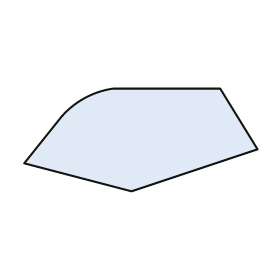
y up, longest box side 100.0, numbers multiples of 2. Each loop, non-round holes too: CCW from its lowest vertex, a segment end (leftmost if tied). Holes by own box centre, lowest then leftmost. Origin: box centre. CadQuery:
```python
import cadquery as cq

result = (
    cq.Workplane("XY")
    .moveTo(-4.0, -22.0)
    .lineTo(50.0, -4.0)
    .lineTo(34.0, 22.0)
    .lineTo(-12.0, 22.0)
    .threePointArc((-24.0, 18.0), (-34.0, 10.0))
    .lineTo(-50.0, -10.0)
    .close()
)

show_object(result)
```